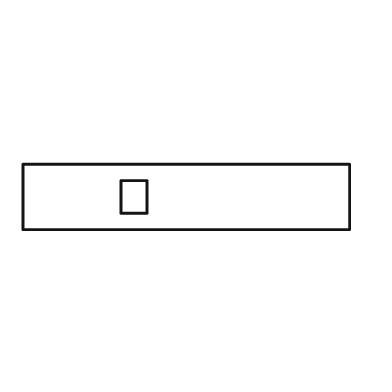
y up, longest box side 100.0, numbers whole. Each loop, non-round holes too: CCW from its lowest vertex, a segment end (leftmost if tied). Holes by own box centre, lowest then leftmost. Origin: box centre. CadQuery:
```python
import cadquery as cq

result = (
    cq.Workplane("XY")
    .moveTo(-50.0, -10.0)
    .lineTo(50.0, -10.0)
    .lineTo(50.0, 10.0)
    .lineTo(-50.0, 10.0)
    .close()
    .moveTo(-20.0, -5.0)
    .lineTo(-12.0, -5.0)
    .lineTo(-12.0, 5.0)
    .lineTo(-20.0, 5.0)
    .close()
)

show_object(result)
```